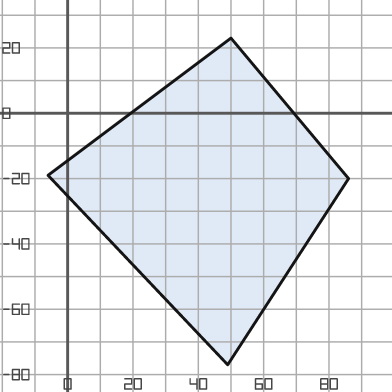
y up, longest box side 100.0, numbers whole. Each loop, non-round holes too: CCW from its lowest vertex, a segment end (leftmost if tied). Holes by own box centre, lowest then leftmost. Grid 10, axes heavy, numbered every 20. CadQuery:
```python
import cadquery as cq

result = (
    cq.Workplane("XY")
    .moveTo(49.0, -77.0)
    .lineTo(86.0, -20.0)
    .lineTo(50.0, 23.0)
    .lineTo(-6.0, -19.0)
    .close()
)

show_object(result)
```